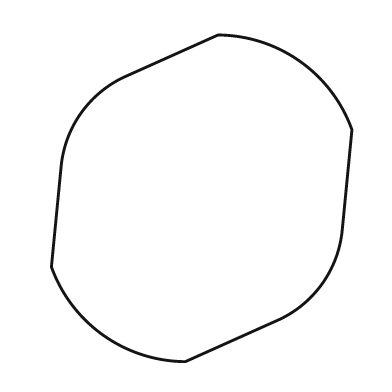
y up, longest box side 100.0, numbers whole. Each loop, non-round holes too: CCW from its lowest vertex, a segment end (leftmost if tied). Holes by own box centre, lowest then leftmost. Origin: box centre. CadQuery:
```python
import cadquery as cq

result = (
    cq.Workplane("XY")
    .moveTo(-5.0, -50.0)
    .lineTo(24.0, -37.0)
    .threePointArc((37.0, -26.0), (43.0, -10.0))
    .lineTo(46.0, 21.0)
    .threePointArc((30.0, 42.0), (5.0, 50.0))
    .lineTo(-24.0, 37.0)
    .threePointArc((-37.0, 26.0), (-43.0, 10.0))
    .lineTo(-46.0, -21.0)
    .threePointArc((-30.0, -42.0), (-5.0, -50.0))
    .close()
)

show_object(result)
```